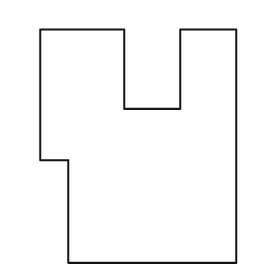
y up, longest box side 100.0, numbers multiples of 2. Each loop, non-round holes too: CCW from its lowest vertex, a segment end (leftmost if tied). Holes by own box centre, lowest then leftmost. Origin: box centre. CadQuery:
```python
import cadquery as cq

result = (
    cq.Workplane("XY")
    .moveTo(-30.0, -50.0)
    .lineTo(42.0, -50.0)
    .lineTo(42.0, 50.0)
    .lineTo(18.0, 50.0)
    .lineTo(18.0, 16.0)
    .lineTo(-6.0, 16.0)
    .lineTo(-6.0, 50.0)
    .lineTo(-42.0, 50.0)
    .lineTo(-42.0, -6.0)
    .lineTo(-30.0, -6.0)
    .close()
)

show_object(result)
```